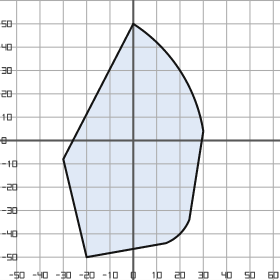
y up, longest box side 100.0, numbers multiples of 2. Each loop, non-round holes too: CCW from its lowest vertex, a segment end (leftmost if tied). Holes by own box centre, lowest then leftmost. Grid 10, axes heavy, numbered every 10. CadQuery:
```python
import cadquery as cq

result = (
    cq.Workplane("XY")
    .moveTo(-20.0, -50.0)
    .lineTo(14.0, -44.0)
    .threePointArc((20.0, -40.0), (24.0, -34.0))
    .lineTo(30.0, 4.0)
    .threePointArc((20.0, 30.0), (0.0, 50.0))
    .lineTo(-30.0, -8.0)
    .close()
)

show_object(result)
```